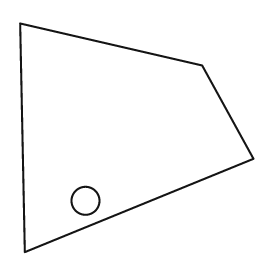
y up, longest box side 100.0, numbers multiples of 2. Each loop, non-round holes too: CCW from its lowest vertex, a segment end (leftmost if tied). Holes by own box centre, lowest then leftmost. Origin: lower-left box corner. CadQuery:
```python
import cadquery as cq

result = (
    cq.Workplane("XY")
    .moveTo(2.0, 0.0)
    .lineTo(100.0, 40.0)
    .lineTo(78.0, 80.0)
    .lineTo(0.0, 98.0)
    .close()
    .moveTo(28.0, 22.0)
    .circle(6.0)
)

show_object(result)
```